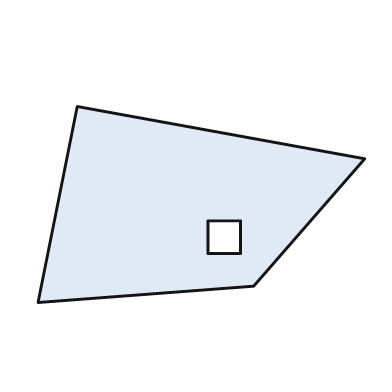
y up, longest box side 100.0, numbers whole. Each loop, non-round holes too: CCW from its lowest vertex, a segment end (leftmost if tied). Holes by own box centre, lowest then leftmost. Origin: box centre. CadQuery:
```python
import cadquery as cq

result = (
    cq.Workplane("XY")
    .moveTo(-50.0, -30.0)
    .lineTo(16.0, -25.0)
    .lineTo(50.0, 14.0)
    .lineTo(-38.0, 30.0)
    .close()
    .moveTo(2.0, -15.0)
    .lineTo(12.0, -15.0)
    .lineTo(12.0, -5.0)
    .lineTo(2.0, -5.0)
    .close()
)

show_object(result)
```